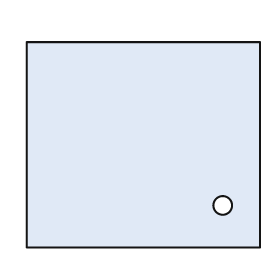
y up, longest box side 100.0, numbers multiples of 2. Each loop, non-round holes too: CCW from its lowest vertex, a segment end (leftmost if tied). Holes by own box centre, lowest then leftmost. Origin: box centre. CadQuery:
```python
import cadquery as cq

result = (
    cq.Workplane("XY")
    .moveTo(-50.0, -44.0)
    .lineTo(50.0, -44.0)
    .lineTo(50.0, 44.0)
    .lineTo(-50.0, 44.0)
    .close()
    .moveTo(34.0, -26.0)
    .circle(4.0)
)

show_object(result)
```